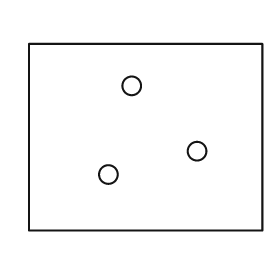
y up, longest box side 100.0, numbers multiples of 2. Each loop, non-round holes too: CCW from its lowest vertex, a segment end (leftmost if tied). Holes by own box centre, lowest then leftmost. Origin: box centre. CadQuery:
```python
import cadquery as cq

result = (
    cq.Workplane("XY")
    .moveTo(-50.0, -40.0)
    .lineTo(50.0, -40.0)
    .lineTo(50.0, 40.0)
    .lineTo(-50.0, 40.0)
    .close()
    .moveTo(-16.0, -16.0)
    .circle(4.0)
    .moveTo(22.0, -6.0)
    .circle(4.0)
    .moveTo(-6.0, 22.0)
    .circle(4.0)
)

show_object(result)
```